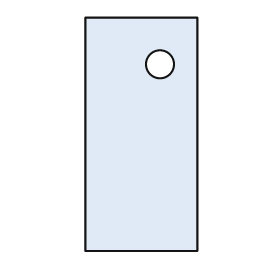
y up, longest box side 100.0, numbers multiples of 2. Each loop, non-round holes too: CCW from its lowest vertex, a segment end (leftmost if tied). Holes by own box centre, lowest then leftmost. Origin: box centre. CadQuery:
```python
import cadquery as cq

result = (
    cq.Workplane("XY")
    .moveTo(-24.0, -50.0)
    .lineTo(24.0, -50.0)
    .lineTo(24.0, 50.0)
    .lineTo(-24.0, 50.0)
    .close()
    .moveTo(8.0, 30.0)
    .circle(6.0)
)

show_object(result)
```